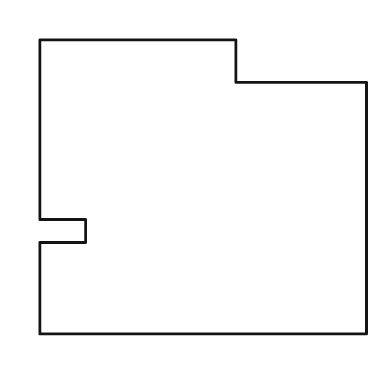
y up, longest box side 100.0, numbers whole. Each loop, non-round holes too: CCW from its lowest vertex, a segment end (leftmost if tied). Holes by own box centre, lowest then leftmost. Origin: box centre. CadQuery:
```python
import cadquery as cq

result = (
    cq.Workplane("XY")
    .moveTo(-50.0, -45.0)
    .lineTo(50.0, -45.0)
    .lineTo(50.0, 32.0)
    .lineTo(10.0, 32.0)
    .lineTo(10.0, 45.0)
    .lineTo(-50.0, 45.0)
    .lineTo(-50.0, -10.0)
    .lineTo(-36.0, -10.0)
    .lineTo(-36.0, -17.0)
    .lineTo(-50.0, -17.0)
    .close()
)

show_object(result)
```